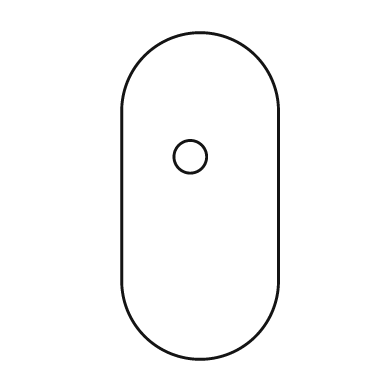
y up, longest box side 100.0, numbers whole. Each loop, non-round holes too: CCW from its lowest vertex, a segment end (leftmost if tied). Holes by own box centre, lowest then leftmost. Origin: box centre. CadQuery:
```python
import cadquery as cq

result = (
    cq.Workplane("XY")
    .moveTo(-24.0, -26.0)
    .threePointArc((0.0, -50.0), (24.0, -26.0))
    .lineTo(24.0, 26.0)
    .threePointArc((0.0, 50.0), (-24.0, 26.0))
    .close()
    .moveTo(-3.0, 12.0)
    .circle(5.0)
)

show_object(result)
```